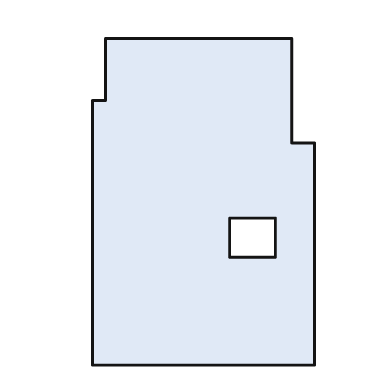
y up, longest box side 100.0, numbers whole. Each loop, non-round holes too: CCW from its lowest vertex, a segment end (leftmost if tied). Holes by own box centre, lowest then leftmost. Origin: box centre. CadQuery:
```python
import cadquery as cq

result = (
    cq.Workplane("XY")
    .moveTo(-34.0, -50.0)
    .lineTo(34.0, -50.0)
    .lineTo(34.0, 18.0)
    .lineTo(27.0, 18.0)
    .lineTo(27.0, 50.0)
    .lineTo(-30.0, 50.0)
    .lineTo(-30.0, 31.0)
    .lineTo(-34.0, 31.0)
    .close()
    .moveTo(8.0, -17.0)
    .lineTo(22.0, -17.0)
    .lineTo(22.0, -5.0)
    .lineTo(8.0, -5.0)
    .close()
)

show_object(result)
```